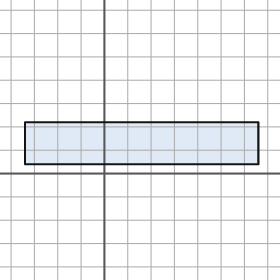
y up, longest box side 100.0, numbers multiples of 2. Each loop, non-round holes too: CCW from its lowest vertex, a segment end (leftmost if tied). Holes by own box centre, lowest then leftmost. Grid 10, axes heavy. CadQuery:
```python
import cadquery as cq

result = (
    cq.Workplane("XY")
    .moveTo(-34.0, 4.0)
    .lineTo(66.0, 4.0)
    .lineTo(66.0, 22.0)
    .lineTo(-34.0, 22.0)
    .close()
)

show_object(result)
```